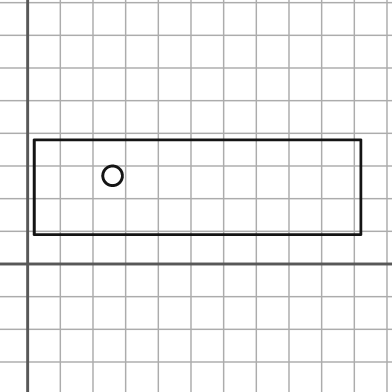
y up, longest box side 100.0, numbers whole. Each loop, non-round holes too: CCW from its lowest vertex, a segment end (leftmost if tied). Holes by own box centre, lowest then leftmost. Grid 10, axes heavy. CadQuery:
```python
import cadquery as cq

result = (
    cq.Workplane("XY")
    .moveTo(2.0, 9.0)
    .lineTo(102.0, 9.0)
    .lineTo(102.0, 38.0)
    .lineTo(2.0, 38.0)
    .close()
    .moveTo(26.0, 27.0)
    .circle(3.0)
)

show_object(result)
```